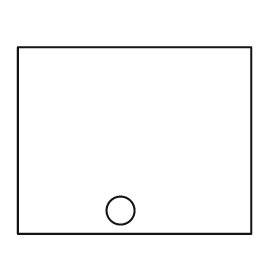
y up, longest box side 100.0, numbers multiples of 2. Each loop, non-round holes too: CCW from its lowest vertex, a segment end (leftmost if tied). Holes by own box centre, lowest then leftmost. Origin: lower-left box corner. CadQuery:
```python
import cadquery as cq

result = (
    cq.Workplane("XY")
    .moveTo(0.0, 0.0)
    .lineTo(100.0, 0.0)
    .lineTo(100.0, 80.0)
    .lineTo(0.0, 80.0)
    .close()
    .moveTo(44.0, 10.0)
    .circle(6.0)
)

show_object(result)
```